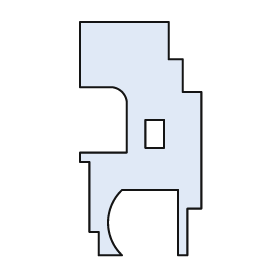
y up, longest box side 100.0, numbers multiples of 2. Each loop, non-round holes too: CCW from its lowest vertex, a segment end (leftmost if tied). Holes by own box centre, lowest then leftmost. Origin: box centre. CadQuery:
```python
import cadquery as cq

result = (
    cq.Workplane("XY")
    .moveTo(-18.0, -50.0)
    .lineTo(-8.0, -50.0)
    .threePointArc((-14.0, -36.0), (-8.0, -22.0))
    .lineTo(16.0, -22.0)
    .lineTo(16.0, -50.0)
    .lineTo(20.0, -50.0)
    .lineTo(20.0, -30.0)
    .lineTo(26.0, -30.0)
    .lineTo(26.0, 20.0)
    .lineTo(18.0, 20.0)
    .lineTo(18.0, 34.0)
    .lineTo(12.0, 34.0)
    .lineTo(12.0, 50.0)
    .lineTo(-26.0, 50.0)
    .lineTo(-26.0, 22.0)
    .lineTo(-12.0, 22.0)
    .threePointArc((-8.0, 20.0), (-6.0, 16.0))
    .lineTo(-6.0, -6.0)
    .lineTo(-26.0, -6.0)
    .lineTo(-26.0, -10.0)
    .lineTo(-22.0, -10.0)
    .lineTo(-22.0, -40.0)
    .lineTo(-18.0, -40.0)
    .close()
    .moveTo(2.0, -4.0)
    .lineTo(10.0, -4.0)
    .lineTo(10.0, 8.0)
    .lineTo(2.0, 8.0)
    .close()
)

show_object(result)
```